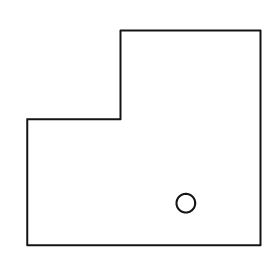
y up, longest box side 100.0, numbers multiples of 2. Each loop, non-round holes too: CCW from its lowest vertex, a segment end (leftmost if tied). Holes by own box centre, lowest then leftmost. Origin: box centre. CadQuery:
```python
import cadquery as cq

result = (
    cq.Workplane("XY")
    .moveTo(-50.0, -46.0)
    .lineTo(50.0, -46.0)
    .lineTo(50.0, 46.0)
    .lineTo(-10.0, 46.0)
    .lineTo(-10.0, 8.0)
    .lineTo(-50.0, 8.0)
    .close()
    .moveTo(18.0, -28.0)
    .circle(4.0)
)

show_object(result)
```